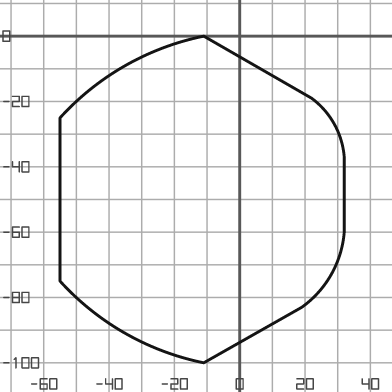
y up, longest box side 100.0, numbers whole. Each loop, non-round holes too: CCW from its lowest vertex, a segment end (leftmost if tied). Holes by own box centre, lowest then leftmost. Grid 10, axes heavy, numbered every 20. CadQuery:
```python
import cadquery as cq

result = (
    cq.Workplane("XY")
    .moveTo(-11.0, -100.0)
    .lineTo(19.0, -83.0)
    .threePointArc((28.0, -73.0), (32.0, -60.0))
    .lineTo(32.0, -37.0)
    .threePointArc((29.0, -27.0), (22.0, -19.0))
    .lineTo(-11.0, 0.0)
    .threePointArc((-35.0, -9.0), (-55.0, -25.0))
    .lineTo(-55.0, -75.0)
    .threePointArc((-35.0, -91.0), (-11.0, -100.0))
    .close()
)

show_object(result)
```